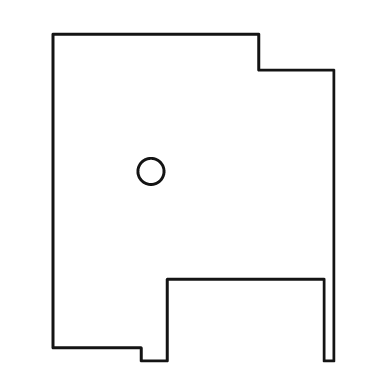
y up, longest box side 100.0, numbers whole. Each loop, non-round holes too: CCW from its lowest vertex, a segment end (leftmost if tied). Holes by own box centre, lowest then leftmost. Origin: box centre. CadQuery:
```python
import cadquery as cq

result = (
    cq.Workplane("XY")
    .moveTo(-16.0, -50.0)
    .lineTo(-8.0, -50.0)
    .lineTo(-8.0, -25.0)
    .lineTo(40.0, -25.0)
    .lineTo(40.0, -50.0)
    .lineTo(43.0, -50.0)
    .lineTo(43.0, 39.0)
    .lineTo(20.0, 39.0)
    .lineTo(20.0, 50.0)
    .lineTo(-43.0, 50.0)
    .lineTo(-43.0, -46.0)
    .lineTo(-16.0, -46.0)
    .close()
    .moveTo(-13.0, 8.0)
    .circle(4.0)
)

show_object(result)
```